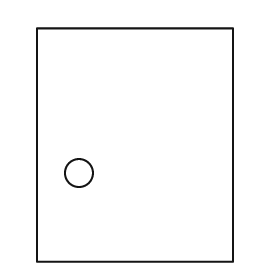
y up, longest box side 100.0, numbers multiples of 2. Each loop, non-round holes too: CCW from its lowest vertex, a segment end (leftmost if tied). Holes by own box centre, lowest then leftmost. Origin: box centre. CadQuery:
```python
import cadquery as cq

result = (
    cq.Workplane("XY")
    .moveTo(-42.0, -50.0)
    .lineTo(42.0, -50.0)
    .lineTo(42.0, 50.0)
    .lineTo(-42.0, 50.0)
    .close()
    .moveTo(-24.0, -12.0)
    .circle(6.0)
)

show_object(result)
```